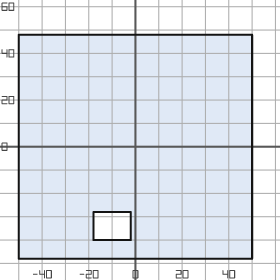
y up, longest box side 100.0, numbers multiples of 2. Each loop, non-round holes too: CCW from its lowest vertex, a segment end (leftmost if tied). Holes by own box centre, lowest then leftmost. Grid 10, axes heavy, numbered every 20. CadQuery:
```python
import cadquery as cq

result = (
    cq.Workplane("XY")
    .moveTo(-50.0, -48.0)
    .lineTo(50.0, -48.0)
    .lineTo(50.0, 48.0)
    .lineTo(-50.0, 48.0)
    .close()
    .moveTo(-18.0, -40.0)
    .lineTo(-2.0, -40.0)
    .lineTo(-2.0, -28.0)
    .lineTo(-18.0, -28.0)
    .close()
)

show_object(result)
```